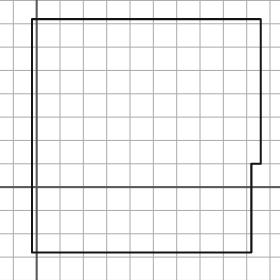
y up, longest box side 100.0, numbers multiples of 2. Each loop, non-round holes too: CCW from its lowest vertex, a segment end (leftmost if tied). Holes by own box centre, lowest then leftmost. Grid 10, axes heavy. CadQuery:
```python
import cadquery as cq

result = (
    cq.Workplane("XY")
    .moveTo(-2.0, -28.0)
    .lineTo(92.0, -28.0)
    .lineTo(92.0, 10.0)
    .lineTo(96.0, 10.0)
    .lineTo(96.0, 72.0)
    .lineTo(-2.0, 72.0)
    .close()
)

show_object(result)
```